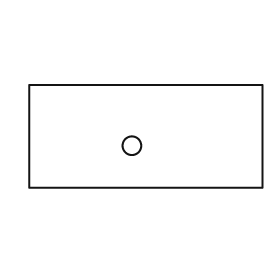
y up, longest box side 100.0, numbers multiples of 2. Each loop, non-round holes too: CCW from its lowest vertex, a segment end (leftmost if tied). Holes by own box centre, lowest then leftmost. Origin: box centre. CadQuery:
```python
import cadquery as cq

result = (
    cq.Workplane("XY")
    .moveTo(-50.0, -22.0)
    .lineTo(50.0, -22.0)
    .lineTo(50.0, 22.0)
    .lineTo(-50.0, 22.0)
    .close()
    .moveTo(-6.0, -4.0)
    .circle(4.0)
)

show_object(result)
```